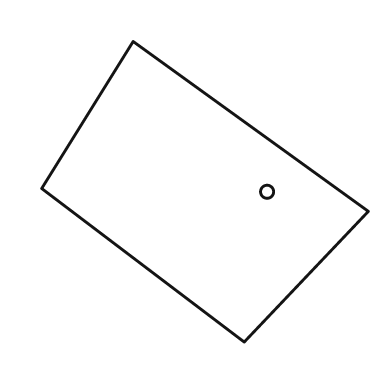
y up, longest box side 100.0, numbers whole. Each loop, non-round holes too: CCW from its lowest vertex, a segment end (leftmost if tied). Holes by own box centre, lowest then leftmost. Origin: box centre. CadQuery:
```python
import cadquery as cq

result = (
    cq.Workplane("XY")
    .moveTo(12.0, -46.0)
    .lineTo(50.0, -6.0)
    .lineTo(-22.0, 46.0)
    .lineTo(-50.0, 1.0)
    .close()
    .moveTo(19.0, 0.0)
    .circle(2.0)
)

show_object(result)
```